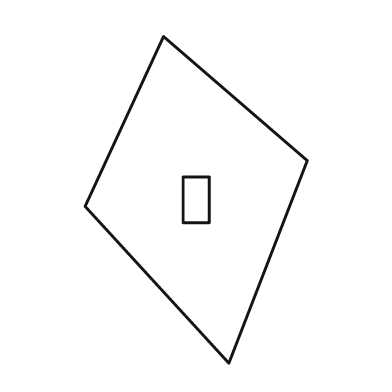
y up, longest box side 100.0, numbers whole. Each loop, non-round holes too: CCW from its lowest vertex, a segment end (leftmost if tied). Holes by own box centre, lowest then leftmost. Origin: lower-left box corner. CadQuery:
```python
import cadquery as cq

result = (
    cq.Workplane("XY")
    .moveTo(44.0, 0.0)
    .lineTo(68.0, 62.0)
    .lineTo(24.0, 100.0)
    .lineTo(0.0, 48.0)
    .close()
    .moveTo(30.0, 43.0)
    .lineTo(38.0, 43.0)
    .lineTo(38.0, 57.0)
    .lineTo(30.0, 57.0)
    .close()
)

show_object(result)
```